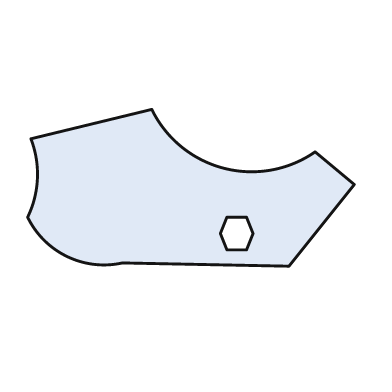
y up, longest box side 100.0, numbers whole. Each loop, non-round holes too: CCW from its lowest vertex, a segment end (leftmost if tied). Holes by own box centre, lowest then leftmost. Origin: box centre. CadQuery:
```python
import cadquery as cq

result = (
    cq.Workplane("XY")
    .moveTo(30.0, -24.0)
    .lineTo(50.0, 1.0)
    .lineTo(38.0, 11.0)
    .threePointArc((10.0, 6.0), (-12.0, 24.0))
    .lineTo(-49.0, 15.0)
    .threePointArc((-47.0, 3.0), (-50.0, -9.0))
    .threePointArc((-38.0, -21.0), (-21.0, -23.0))
    .close()
    .moveTo(11.0, -19.0)
    .lineTo(17.0, -19.0)
    .lineTo(19.0, -14.0)
    .lineTo(17.0, -9.0)
    .lineTo(11.0, -9.0)
    .lineTo(9.0, -14.0)
    .close()
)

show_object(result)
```